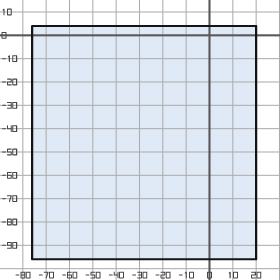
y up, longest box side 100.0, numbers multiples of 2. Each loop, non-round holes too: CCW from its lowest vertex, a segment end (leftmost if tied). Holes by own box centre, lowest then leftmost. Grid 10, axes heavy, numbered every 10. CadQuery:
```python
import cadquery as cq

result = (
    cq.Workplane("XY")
    .moveTo(-76.0, -96.0)
    .lineTo(20.0, -96.0)
    .lineTo(20.0, 4.0)
    .lineTo(-76.0, 4.0)
    .close()
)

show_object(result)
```